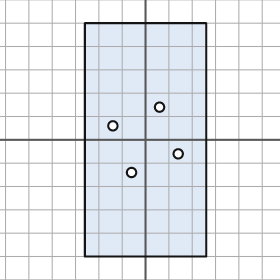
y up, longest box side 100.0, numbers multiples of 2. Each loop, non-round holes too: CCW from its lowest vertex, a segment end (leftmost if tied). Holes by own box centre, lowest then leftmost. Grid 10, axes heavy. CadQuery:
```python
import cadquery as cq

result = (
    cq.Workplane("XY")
    .moveTo(-26.0, -50.0)
    .lineTo(26.0, -50.0)
    .lineTo(26.0, 50.0)
    .lineTo(-26.0, 50.0)
    .close()
    .moveTo(-6.0, -14.0)
    .circle(2.0)
    .moveTo(14.0, -6.0)
    .circle(2.0)
    .moveTo(-14.0, 6.0)
    .circle(2.0)
    .moveTo(6.0, 14.0)
    .circle(2.0)
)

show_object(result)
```